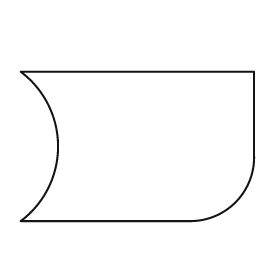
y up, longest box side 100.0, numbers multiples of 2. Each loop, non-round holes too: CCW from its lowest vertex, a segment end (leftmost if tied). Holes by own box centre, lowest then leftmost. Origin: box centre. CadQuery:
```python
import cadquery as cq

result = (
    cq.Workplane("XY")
    .moveTo(-50.0, -32.0)
    .lineTo(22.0, -32.0)
    .threePointArc((42.0, -24.0), (50.0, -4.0))
    .lineTo(50.0, 32.0)
    .lineTo(-50.0, 32.0)
    .threePointArc((-34.0, 0.0), (-50.0, -32.0))
    .close()
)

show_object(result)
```